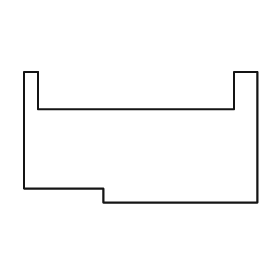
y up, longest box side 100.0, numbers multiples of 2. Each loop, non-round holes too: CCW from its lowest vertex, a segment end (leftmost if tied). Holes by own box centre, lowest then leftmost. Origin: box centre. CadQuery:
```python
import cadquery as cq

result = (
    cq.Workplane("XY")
    .moveTo(-16.0, -28.0)
    .lineTo(50.0, -28.0)
    .lineTo(50.0, 28.0)
    .lineTo(40.0, 28.0)
    .lineTo(40.0, 12.0)
    .lineTo(-44.0, 12.0)
    .lineTo(-44.0, 28.0)
    .lineTo(-50.0, 28.0)
    .lineTo(-50.0, -22.0)
    .lineTo(-16.0, -22.0)
    .close()
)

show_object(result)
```